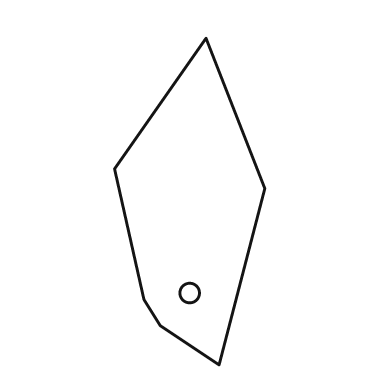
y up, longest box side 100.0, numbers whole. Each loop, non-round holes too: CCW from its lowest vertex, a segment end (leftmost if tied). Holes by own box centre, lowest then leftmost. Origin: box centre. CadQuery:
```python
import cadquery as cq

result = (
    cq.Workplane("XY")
    .moveTo(9.0, -50.0)
    .lineTo(23.0, 4.0)
    .lineTo(5.0, 50.0)
    .lineTo(-23.0, 10.0)
    .lineTo(-14.0, -30.0)
    .lineTo(-9.0, -38.0)
    .close()
    .moveTo(0.0, -28.0)
    .circle(3.0)
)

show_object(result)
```